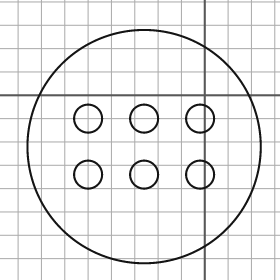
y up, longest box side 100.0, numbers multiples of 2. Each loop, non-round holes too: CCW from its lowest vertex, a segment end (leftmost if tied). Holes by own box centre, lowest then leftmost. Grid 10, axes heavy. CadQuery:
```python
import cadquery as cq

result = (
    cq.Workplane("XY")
    .moveTo(-26.0, -22.0)
    .circle(50.0)
    .moveTo(-50.0, -34.0)
    .circle(6.0)
    .moveTo(-26.0, -34.0)
    .circle(6.0)
    .moveTo(-2.0, -34.0)
    .circle(6.0)
    .moveTo(-50.0, -10.0)
    .circle(6.0)
    .moveTo(-26.0, -10.0)
    .circle(6.0)
    .moveTo(-2.0, -10.0)
    .circle(6.0)
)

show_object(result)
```